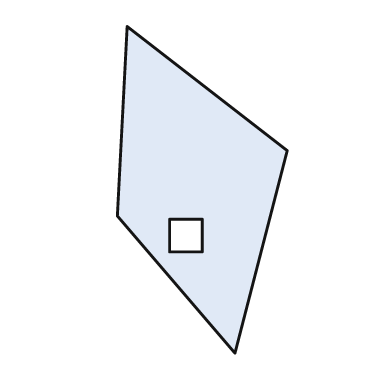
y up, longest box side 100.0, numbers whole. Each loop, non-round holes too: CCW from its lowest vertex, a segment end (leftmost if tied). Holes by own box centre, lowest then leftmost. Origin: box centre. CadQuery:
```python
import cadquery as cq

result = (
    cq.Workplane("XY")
    .moveTo(10.0, -50.0)
    .lineTo(26.0, 12.0)
    .lineTo(-23.0, 50.0)
    .lineTo(-26.0, -8.0)
    .close()
    .moveTo(-10.0, -19.0)
    .lineTo(0.0, -19.0)
    .lineTo(0.0, -9.0)
    .lineTo(-10.0, -9.0)
    .close()
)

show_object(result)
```